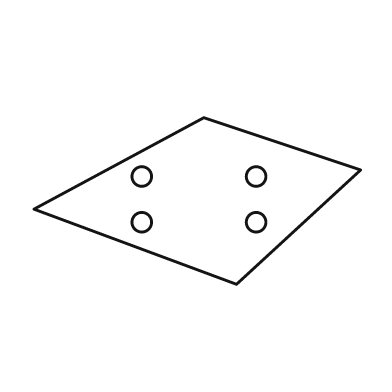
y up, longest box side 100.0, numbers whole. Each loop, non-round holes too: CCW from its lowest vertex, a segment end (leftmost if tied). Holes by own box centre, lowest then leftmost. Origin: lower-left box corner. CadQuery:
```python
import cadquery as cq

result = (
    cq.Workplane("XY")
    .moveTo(62.0, 0.0)
    .lineTo(100.0, 35.0)
    .lineTo(52.0, 51.0)
    .lineTo(0.0, 23.0)
    .close()
    .moveTo(33.0, 19.0)
    .circle(3.0)
    .moveTo(68.0, 19.0)
    .circle(3.0)
    .moveTo(33.0, 33.0)
    .circle(3.0)
    .moveTo(68.0, 33.0)
    .circle(3.0)
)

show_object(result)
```